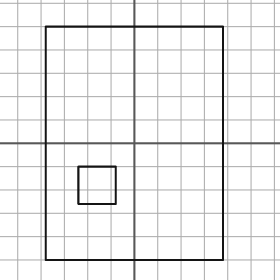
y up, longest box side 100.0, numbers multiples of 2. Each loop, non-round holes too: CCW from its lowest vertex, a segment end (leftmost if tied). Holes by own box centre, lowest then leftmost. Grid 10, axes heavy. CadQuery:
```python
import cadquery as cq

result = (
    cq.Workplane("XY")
    .moveTo(-38.0, -50.0)
    .lineTo(38.0, -50.0)
    .lineTo(38.0, 50.0)
    .lineTo(-38.0, 50.0)
    .close()
    .moveTo(-24.0, -26.0)
    .lineTo(-8.0, -26.0)
    .lineTo(-8.0, -10.0)
    .lineTo(-24.0, -10.0)
    .close()
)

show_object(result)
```